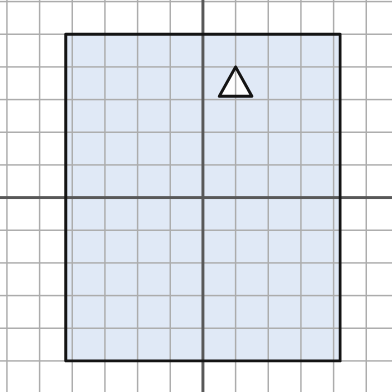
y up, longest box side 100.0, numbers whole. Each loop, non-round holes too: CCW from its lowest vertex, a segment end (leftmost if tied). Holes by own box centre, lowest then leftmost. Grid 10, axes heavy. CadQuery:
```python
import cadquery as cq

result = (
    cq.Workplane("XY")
    .moveTo(-42.0, -50.0)
    .lineTo(42.0, -50.0)
    .lineTo(42.0, 50.0)
    .lineTo(-42.0, 50.0)
    .close()
    .moveTo(5.0, 31.0)
    .lineTo(15.0, 31.0)
    .lineTo(10.0, 40.0)
    .close()
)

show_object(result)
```